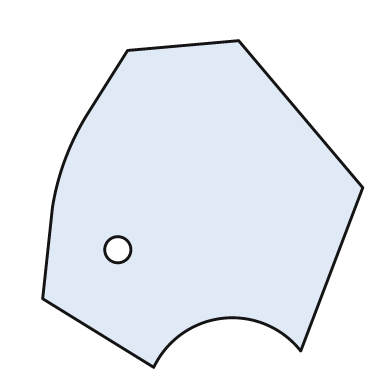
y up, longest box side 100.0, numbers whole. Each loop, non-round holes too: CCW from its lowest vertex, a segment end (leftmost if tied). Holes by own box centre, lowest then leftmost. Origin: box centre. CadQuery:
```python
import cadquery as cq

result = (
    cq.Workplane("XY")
    .moveTo(-15.0, -50.0)
    .threePointArc((6.0, -35.0), (30.0, -45.0))
    .lineTo(49.0, 5.0)
    .lineTo(11.0, 50.0)
    .lineTo(-23.0, 47.0)
    .lineTo(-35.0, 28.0)
    .threePointArc((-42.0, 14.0), (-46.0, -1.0))
    .lineTo(-49.0, -29.0)
    .close()
    .moveTo(-26.0, -14.0)
    .circle(4.0)
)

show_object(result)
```